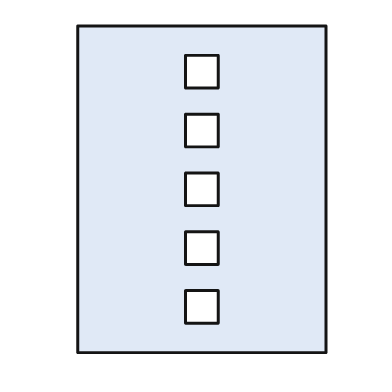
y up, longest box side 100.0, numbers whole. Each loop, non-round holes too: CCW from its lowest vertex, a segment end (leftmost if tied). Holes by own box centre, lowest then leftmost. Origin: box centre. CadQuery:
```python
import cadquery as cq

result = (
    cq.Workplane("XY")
    .moveTo(-38.0, -50.0)
    .lineTo(38.0, -50.0)
    .lineTo(38.0, 50.0)
    .lineTo(-38.0, 50.0)
    .close()
    .moveTo(-5.0, -41.0)
    .lineTo(5.0, -41.0)
    .lineTo(5.0, -31.0)
    .lineTo(-5.0, -31.0)
    .close()
    .moveTo(-5.0, -23.0)
    .lineTo(5.0, -23.0)
    .lineTo(5.0, -13.0)
    .lineTo(-5.0, -13.0)
    .close()
    .moveTo(-5.0, -5.0)
    .lineTo(5.0, -5.0)
    .lineTo(5.0, 5.0)
    .lineTo(-5.0, 5.0)
    .close()
    .moveTo(-5.0, 13.0)
    .lineTo(5.0, 13.0)
    .lineTo(5.0, 23.0)
    .lineTo(-5.0, 23.0)
    .close()
    .moveTo(-5.0, 31.0)
    .lineTo(5.0, 31.0)
    .lineTo(5.0, 41.0)
    .lineTo(-5.0, 41.0)
    .close()
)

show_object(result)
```